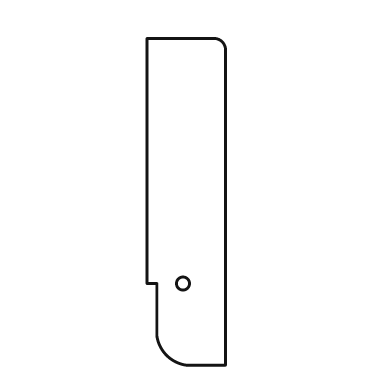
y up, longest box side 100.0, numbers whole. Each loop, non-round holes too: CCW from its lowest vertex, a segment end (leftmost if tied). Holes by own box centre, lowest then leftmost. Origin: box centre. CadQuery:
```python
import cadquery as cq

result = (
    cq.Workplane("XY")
    .moveTo(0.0, -50.0)
    .lineTo(12.0, -50.0)
    .lineTo(12.0, 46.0)
    .threePointArc((11.0, 49.0), (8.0, 50.0))
    .lineTo(-12.0, 50.0)
    .lineTo(-12.0, -25.0)
    .lineTo(-9.0, -25.0)
    .lineTo(-9.0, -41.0)
    .threePointArc((-6.0, -47.0), (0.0, -50.0))
    .close()
    .moveTo(-1.0, -25.0)
    .circle(2.0)
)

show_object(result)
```